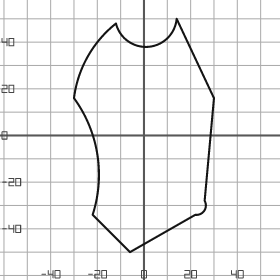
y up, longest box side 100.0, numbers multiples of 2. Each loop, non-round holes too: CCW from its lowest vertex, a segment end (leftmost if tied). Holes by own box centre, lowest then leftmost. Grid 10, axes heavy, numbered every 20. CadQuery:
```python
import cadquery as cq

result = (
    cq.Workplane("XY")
    .moveTo(-6.0, -50.0)
    .lineTo(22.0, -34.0)
    .threePointArc((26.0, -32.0), (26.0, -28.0))
    .lineTo(30.0, 16.0)
    .lineTo(14.0, 50.0)
    .threePointArc((2.0, 38.0), (-12.0, 48.0))
    .threePointArc((-24.0, 34.0), (-30.0, 16.0))
    .threePointArc((-20.0, -8.0), (-22.0, -34.0))
    .close()
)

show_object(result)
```